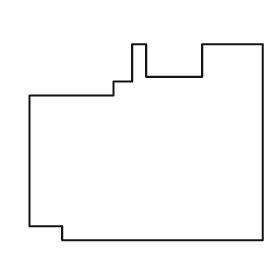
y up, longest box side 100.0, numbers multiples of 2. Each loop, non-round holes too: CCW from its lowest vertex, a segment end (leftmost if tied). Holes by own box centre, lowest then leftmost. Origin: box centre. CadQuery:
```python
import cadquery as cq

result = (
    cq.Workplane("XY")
    .moveTo(-36.0, -42.0)
    .lineTo(50.0, -42.0)
    .lineTo(50.0, 42.0)
    .lineTo(24.0, 42.0)
    .lineTo(24.0, 28.0)
    .lineTo(0.0, 28.0)
    .lineTo(0.0, 42.0)
    .lineTo(-6.0, 42.0)
    .lineTo(-6.0, 26.0)
    .lineTo(-14.0, 26.0)
    .lineTo(-14.0, 20.0)
    .lineTo(-50.0, 20.0)
    .lineTo(-50.0, -36.0)
    .lineTo(-36.0, -36.0)
    .close()
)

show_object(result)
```